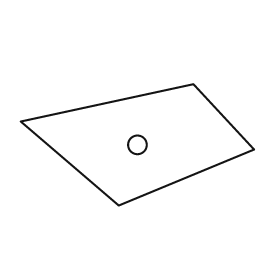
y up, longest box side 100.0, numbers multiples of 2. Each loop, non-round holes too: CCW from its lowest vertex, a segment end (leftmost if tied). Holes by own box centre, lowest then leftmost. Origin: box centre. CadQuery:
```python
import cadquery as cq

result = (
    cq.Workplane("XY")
    .moveTo(-8.0, -26.0)
    .lineTo(50.0, -2.0)
    .lineTo(24.0, 26.0)
    .lineTo(-50.0, 10.0)
    .close()
    .moveTo(0.0, 0.0)
    .circle(4.0)
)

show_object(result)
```